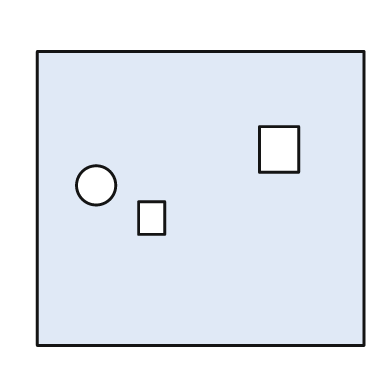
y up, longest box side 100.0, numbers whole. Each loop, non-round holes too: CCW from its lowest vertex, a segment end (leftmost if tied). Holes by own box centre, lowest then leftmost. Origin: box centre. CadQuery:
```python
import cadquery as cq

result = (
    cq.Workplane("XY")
    .moveTo(-50.0, -45.0)
    .lineTo(50.0, -45.0)
    .lineTo(50.0, 45.0)
    .lineTo(-50.0, 45.0)
    .close()
    .moveTo(-19.0, -11.0)
    .lineTo(-11.0, -11.0)
    .lineTo(-11.0, -1.0)
    .lineTo(-19.0, -1.0)
    .close()
    .moveTo(-32.0, 4.0)
    .circle(6.0)
    .moveTo(18.0, 8.0)
    .lineTo(30.0, 8.0)
    .lineTo(30.0, 22.0)
    .lineTo(18.0, 22.0)
    .close()
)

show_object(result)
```